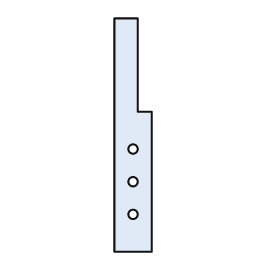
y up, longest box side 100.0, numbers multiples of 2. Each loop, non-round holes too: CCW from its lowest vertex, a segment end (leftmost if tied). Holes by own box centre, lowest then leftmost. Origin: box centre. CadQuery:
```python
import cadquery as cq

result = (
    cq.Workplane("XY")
    .moveTo(-8.0, -50.0)
    .lineTo(8.0, -50.0)
    .lineTo(8.0, 10.0)
    .lineTo(2.0, 10.0)
    .lineTo(2.0, 50.0)
    .lineTo(-8.0, 50.0)
    .close()
    .moveTo(0.0, -34.0)
    .circle(2.0)
    .moveTo(0.0, -20.0)
    .circle(2.0)
    .moveTo(0.0, -6.0)
    .circle(2.0)
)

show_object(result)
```